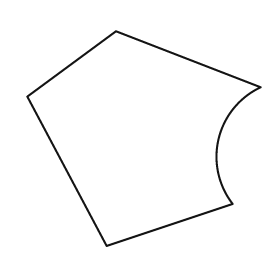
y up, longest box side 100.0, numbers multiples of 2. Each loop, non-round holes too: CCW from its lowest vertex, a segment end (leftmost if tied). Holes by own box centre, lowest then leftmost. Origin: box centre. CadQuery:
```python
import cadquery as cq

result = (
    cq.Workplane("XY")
    .moveTo(-16.0, -46.0)
    .lineTo(38.0, -28.0)
    .threePointArc((32.0, 0.0), (50.0, 22.0))
    .lineTo(-12.0, 46.0)
    .lineTo(-50.0, 18.0)
    .close()
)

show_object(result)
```